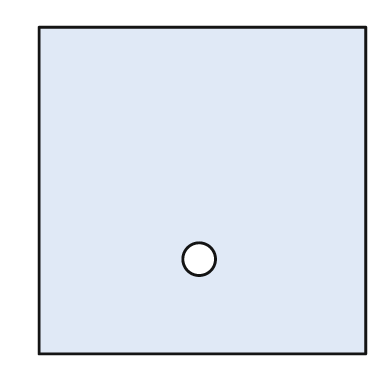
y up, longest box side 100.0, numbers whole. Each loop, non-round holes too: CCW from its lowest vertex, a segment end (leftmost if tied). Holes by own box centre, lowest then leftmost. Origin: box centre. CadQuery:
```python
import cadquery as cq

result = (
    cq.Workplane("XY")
    .moveTo(-50.0, -50.0)
    .lineTo(50.0, -50.0)
    .lineTo(50.0, 50.0)
    .lineTo(-50.0, 50.0)
    .close()
    .moveTo(-1.0, -21.0)
    .circle(5.0)
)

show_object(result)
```